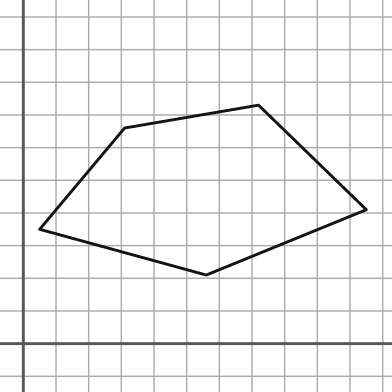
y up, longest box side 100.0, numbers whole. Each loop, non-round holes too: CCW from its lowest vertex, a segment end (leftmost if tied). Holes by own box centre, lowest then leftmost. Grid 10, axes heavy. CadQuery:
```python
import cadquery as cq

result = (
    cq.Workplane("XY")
    .moveTo(56.0, 21.0)
    .lineTo(105.0, 41.0)
    .lineTo(72.0, 73.0)
    .lineTo(31.0, 66.0)
    .lineTo(5.0, 35.0)
    .close()
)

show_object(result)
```